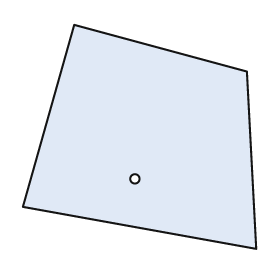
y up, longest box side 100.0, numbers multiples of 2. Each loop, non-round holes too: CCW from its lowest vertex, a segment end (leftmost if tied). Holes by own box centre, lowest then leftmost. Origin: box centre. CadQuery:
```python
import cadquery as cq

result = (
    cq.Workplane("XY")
    .moveTo(50.0, -48.0)
    .lineTo(46.0, 28.0)
    .lineTo(-28.0, 48.0)
    .lineTo(-50.0, -30.0)
    .close()
    .moveTo(-2.0, -18.0)
    .circle(2.0)
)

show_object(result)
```